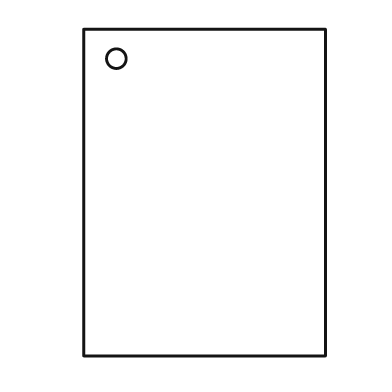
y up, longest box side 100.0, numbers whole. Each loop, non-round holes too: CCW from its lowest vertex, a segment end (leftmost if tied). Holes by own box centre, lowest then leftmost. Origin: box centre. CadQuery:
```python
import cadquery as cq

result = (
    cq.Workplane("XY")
    .moveTo(-37.0, -50.0)
    .lineTo(37.0, -50.0)
    .lineTo(37.0, 50.0)
    .lineTo(-37.0, 50.0)
    .close()
    .moveTo(-27.0, 41.0)
    .circle(3.0)
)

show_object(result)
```